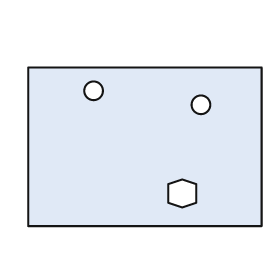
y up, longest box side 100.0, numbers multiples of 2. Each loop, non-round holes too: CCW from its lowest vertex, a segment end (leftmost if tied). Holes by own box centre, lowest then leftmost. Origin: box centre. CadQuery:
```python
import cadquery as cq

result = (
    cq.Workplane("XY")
    .moveTo(-50.0, -34.0)
    .lineTo(50.0, -34.0)
    .lineTo(50.0, 34.0)
    .lineTo(-50.0, 34.0)
    .close()
    .moveTo(16.0, -26.0)
    .lineTo(22.0, -24.0)
    .lineTo(22.0, -16.0)
    .lineTo(16.0, -14.0)
    .lineTo(10.0, -16.0)
    .lineTo(10.0, -24.0)
    .close()
    .moveTo(24.0, 18.0)
    .circle(4.0)
    .moveTo(-22.0, 24.0)
    .circle(4.0)
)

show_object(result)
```